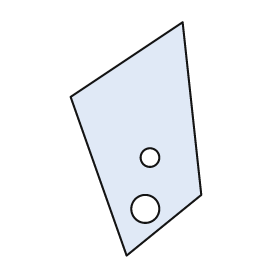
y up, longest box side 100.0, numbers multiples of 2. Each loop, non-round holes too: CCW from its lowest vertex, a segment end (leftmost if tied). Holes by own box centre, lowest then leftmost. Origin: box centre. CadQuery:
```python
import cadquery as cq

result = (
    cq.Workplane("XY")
    .moveTo(-4.0, -50.0)
    .lineTo(28.0, -24.0)
    .lineTo(20.0, 50.0)
    .lineTo(-28.0, 18.0)
    .close()
    .moveTo(4.0, -30.0)
    .circle(6.0)
    .moveTo(6.0, -8.0)
    .circle(4.0)
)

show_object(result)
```